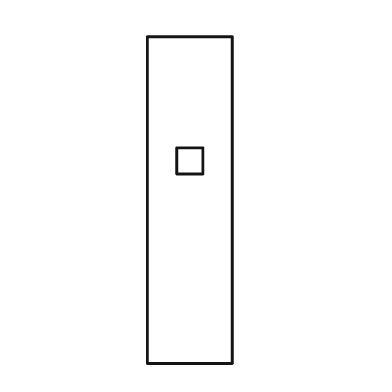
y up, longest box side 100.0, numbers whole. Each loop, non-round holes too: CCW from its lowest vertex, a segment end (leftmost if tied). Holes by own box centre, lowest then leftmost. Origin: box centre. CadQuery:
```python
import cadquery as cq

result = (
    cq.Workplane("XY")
    .moveTo(-13.0, -50.0)
    .lineTo(13.0, -50.0)
    .lineTo(13.0, 50.0)
    .lineTo(-13.0, 50.0)
    .close()
    .moveTo(-4.0, 8.0)
    .lineTo(4.0, 8.0)
    .lineTo(4.0, 16.0)
    .lineTo(-4.0, 16.0)
    .close()
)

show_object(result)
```